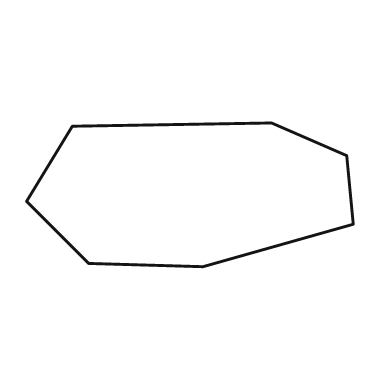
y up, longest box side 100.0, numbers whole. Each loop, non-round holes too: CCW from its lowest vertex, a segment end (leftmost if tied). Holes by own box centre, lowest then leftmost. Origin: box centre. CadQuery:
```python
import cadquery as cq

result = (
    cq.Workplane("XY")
    .moveTo(4.0, -22.0)
    .lineTo(50.0, -9.0)
    .lineTo(48.0, 12.0)
    .lineTo(25.0, 22.0)
    .lineTo(-36.0, 21.0)
    .lineTo(-50.0, -2.0)
    .lineTo(-31.0, -21.0)
    .close()
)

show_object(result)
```